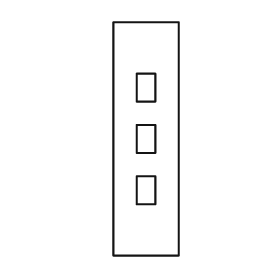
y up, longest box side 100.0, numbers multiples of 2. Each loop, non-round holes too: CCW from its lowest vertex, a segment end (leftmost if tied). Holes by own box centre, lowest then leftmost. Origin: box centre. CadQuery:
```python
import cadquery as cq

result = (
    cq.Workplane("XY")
    .moveTo(-14.0, -50.0)
    .lineTo(14.0, -50.0)
    .lineTo(14.0, 50.0)
    .lineTo(-14.0, 50.0)
    .close()
    .moveTo(-4.0, -28.0)
    .lineTo(4.0, -28.0)
    .lineTo(4.0, -16.0)
    .lineTo(-4.0, -16.0)
    .close()
    .moveTo(-4.0, -6.0)
    .lineTo(4.0, -6.0)
    .lineTo(4.0, 6.0)
    .lineTo(-4.0, 6.0)
    .close()
    .moveTo(-4.0, 16.0)
    .lineTo(4.0, 16.0)
    .lineTo(4.0, 28.0)
    .lineTo(-4.0, 28.0)
    .close()
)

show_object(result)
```